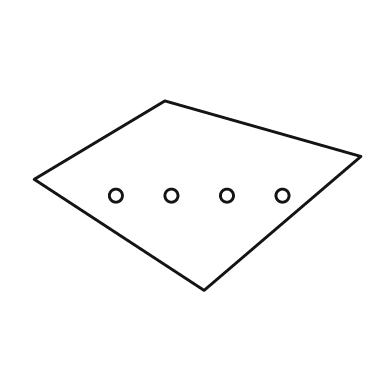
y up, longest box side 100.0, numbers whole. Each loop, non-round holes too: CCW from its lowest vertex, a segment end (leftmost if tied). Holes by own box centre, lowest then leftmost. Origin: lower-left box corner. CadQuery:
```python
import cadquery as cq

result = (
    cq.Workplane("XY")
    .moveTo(52.0, 0.0)
    .lineTo(100.0, 41.0)
    .lineTo(40.0, 58.0)
    .lineTo(0.0, 34.0)
    .close()
    .moveTo(25.0, 29.0)
    .circle(2.0)
    .moveTo(42.0, 29.0)
    .circle(2.0)
    .moveTo(59.0, 29.0)
    .circle(2.0)
    .moveTo(76.0, 29.0)
    .circle(2.0)
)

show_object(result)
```